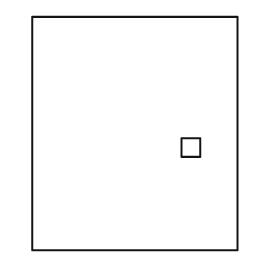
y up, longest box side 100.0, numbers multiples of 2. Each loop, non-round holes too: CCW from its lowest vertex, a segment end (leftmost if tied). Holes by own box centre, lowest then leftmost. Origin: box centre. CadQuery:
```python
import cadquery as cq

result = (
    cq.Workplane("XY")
    .moveTo(-44.0, -50.0)
    .lineTo(44.0, -50.0)
    .lineTo(44.0, 50.0)
    .lineTo(-44.0, 50.0)
    .close()
    .moveTo(20.0, -10.0)
    .lineTo(28.0, -10.0)
    .lineTo(28.0, -2.0)
    .lineTo(20.0, -2.0)
    .close()
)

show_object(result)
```